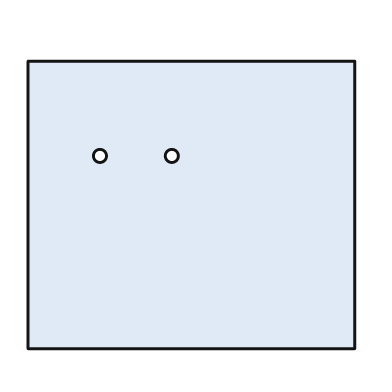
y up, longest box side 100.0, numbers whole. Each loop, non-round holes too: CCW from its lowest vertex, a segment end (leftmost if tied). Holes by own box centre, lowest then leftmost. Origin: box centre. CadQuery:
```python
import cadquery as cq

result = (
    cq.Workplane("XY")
    .moveTo(-50.0, -44.0)
    .lineTo(50.0, -44.0)
    .lineTo(50.0, 44.0)
    .lineTo(-50.0, 44.0)
    .close()
    .moveTo(-28.0, 15.0)
    .circle(2.0)
    .moveTo(-6.0, 15.0)
    .circle(2.0)
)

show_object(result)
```